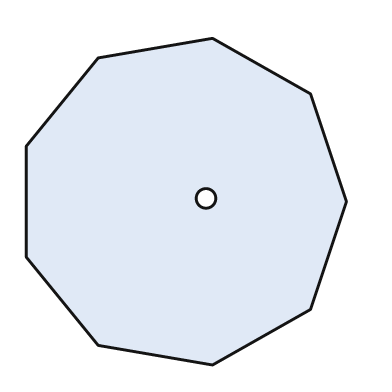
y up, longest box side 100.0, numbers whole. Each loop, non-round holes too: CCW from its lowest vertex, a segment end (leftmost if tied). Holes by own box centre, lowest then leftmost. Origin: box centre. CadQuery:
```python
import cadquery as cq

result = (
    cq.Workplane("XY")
    .moveTo(8.0, -50.0)
    .lineTo(38.0, -33.0)
    .lineTo(49.0, 0.0)
    .lineTo(38.0, 33.0)
    .lineTo(8.0, 50.0)
    .lineTo(-27.0, 44.0)
    .lineTo(-49.0, 17.0)
    .lineTo(-49.0, -17.0)
    .lineTo(-27.0, -44.0)
    .close()
    .moveTo(6.0, 1.0)
    .circle(3.0)
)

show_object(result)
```